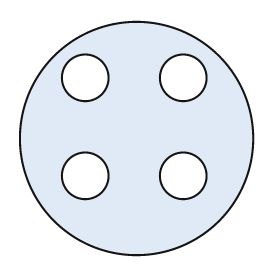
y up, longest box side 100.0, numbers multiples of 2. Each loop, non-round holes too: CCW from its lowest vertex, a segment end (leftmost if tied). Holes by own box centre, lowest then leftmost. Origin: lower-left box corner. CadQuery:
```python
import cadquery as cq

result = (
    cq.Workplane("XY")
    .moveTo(50.0, 50.0)
    .circle(50.0)
    .moveTo(28.0, 34.0)
    .circle(10.0)
    .moveTo(70.0, 34.0)
    .circle(10.0)
    .moveTo(28.0, 76.0)
    .circle(10.0)
    .moveTo(70.0, 76.0)
    .circle(10.0)
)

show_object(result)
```